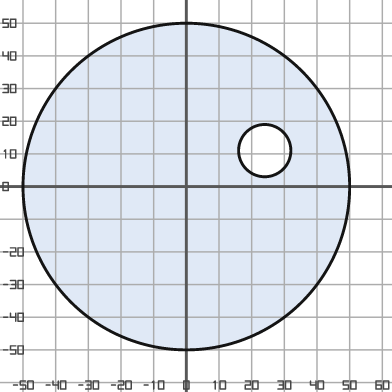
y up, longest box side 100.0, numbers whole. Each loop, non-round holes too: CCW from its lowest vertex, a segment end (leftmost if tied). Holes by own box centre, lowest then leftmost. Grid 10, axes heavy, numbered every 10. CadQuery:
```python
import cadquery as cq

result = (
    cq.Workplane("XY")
    .moveTo(0.0, 0.0)
    .circle(50.0)
    .moveTo(24.0, 11.0)
    .circle(8.0)
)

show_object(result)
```